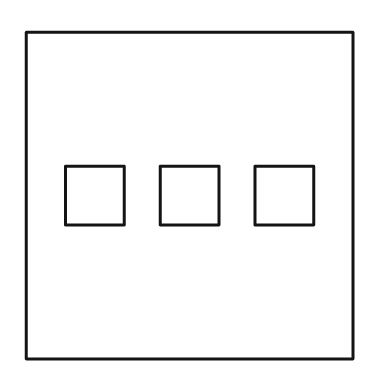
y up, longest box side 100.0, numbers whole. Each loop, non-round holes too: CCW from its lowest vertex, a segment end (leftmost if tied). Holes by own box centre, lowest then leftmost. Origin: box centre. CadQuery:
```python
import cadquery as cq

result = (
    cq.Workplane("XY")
    .moveTo(-50.0, -50.0)
    .lineTo(50.0, -50.0)
    .lineTo(50.0, 50.0)
    .lineTo(-50.0, 50.0)
    .close()
    .moveTo(-38.0, -9.0)
    .lineTo(-20.0, -9.0)
    .lineTo(-20.0, 9.0)
    .lineTo(-38.0, 9.0)
    .close()
    .moveTo(-9.0, -9.0)
    .lineTo(9.0, -9.0)
    .lineTo(9.0, 9.0)
    .lineTo(-9.0, 9.0)
    .close()
    .moveTo(20.0, -9.0)
    .lineTo(38.0, -9.0)
    .lineTo(38.0, 9.0)
    .lineTo(20.0, 9.0)
    .close()
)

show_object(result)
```